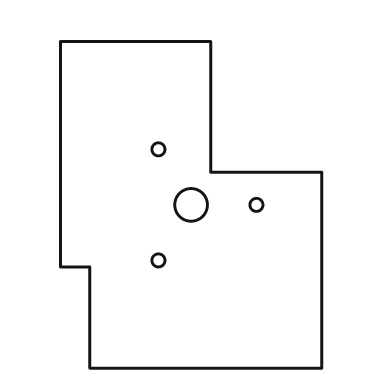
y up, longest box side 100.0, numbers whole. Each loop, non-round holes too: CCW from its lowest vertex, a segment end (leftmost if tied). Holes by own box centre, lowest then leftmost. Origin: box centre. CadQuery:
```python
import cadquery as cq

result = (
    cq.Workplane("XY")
    .moveTo(-31.0, -50.0)
    .lineTo(40.0, -50.0)
    .lineTo(40.0, 10.0)
    .lineTo(6.0, 10.0)
    .lineTo(6.0, 50.0)
    .lineTo(-40.0, 50.0)
    .lineTo(-40.0, -19.0)
    .lineTo(-31.0, -19.0)
    .close()
    .moveTo(-10.0, -17.0)
    .circle(2.0)
    .moveTo(0.0, 0.0)
    .circle(5.0)
    .moveTo(20.0, 0.0)
    .circle(2.0)
    .moveTo(-10.0, 17.0)
    .circle(2.0)
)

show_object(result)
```